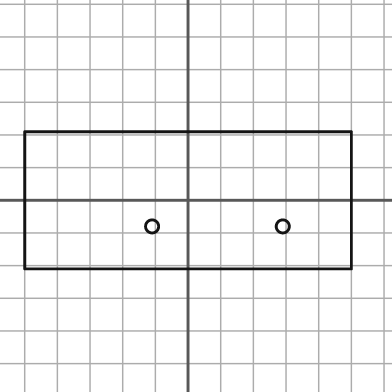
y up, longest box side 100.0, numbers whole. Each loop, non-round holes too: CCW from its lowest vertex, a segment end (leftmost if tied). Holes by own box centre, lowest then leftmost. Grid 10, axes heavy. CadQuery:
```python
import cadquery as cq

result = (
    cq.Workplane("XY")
    .moveTo(-50.0, -21.0)
    .lineTo(50.0, -21.0)
    .lineTo(50.0, 21.0)
    .lineTo(-50.0, 21.0)
    .close()
    .moveTo(-11.0, -8.0)
    .circle(2.0)
    .moveTo(29.0, -8.0)
    .circle(2.0)
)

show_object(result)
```